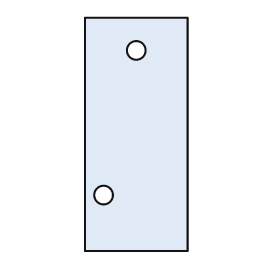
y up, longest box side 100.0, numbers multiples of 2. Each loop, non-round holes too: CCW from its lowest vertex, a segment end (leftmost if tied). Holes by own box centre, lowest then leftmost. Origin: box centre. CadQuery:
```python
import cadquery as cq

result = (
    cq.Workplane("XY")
    .moveTo(-22.0, -50.0)
    .lineTo(22.0, -50.0)
    .lineTo(22.0, 50.0)
    .lineTo(-22.0, 50.0)
    .close()
    .moveTo(-14.0, -26.0)
    .circle(4.0)
    .moveTo(0.0, 36.0)
    .circle(4.0)
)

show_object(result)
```